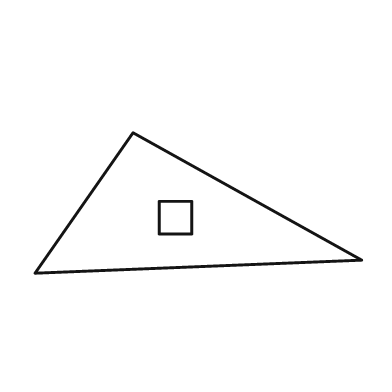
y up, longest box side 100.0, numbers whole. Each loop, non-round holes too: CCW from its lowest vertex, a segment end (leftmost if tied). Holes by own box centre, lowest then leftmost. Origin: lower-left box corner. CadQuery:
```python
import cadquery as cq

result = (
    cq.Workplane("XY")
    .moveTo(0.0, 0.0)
    .lineTo(100.0, 4.0)
    .lineTo(30.0, 43.0)
    .close()
    .moveTo(38.0, 12.0)
    .lineTo(48.0, 12.0)
    .lineTo(48.0, 22.0)
    .lineTo(38.0, 22.0)
    .close()
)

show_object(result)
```